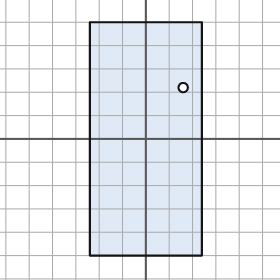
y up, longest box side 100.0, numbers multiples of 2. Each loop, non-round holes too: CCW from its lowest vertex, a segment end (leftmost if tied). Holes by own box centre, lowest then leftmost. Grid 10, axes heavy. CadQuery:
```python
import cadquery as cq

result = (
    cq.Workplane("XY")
    .moveTo(-24.0, -50.0)
    .lineTo(24.0, -50.0)
    .lineTo(24.0, 50.0)
    .lineTo(-24.0, 50.0)
    .close()
    .moveTo(16.0, 22.0)
    .circle(2.0)
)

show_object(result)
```